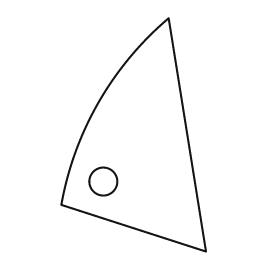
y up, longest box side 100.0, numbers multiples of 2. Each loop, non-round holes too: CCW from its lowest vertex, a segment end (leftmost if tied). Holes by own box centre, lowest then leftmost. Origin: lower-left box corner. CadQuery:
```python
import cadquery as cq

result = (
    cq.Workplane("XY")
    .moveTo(62.0, 0.0)
    .lineTo(46.0, 100.0)
    .threePointArc((16.0, 64.0), (0.0, 20.0))
    .close()
    .moveTo(18.0, 30.0)
    .circle(6.0)
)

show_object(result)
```